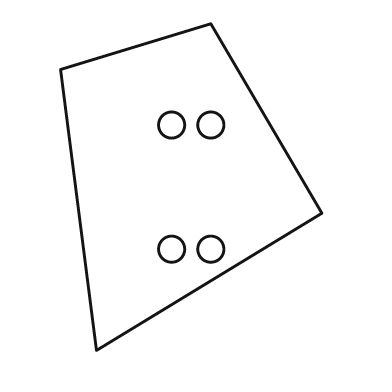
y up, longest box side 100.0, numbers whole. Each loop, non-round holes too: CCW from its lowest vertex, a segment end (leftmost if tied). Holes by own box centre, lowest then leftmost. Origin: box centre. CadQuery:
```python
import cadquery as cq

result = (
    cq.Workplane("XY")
    .moveTo(-29.0, -50.0)
    .lineTo(40.0, -8.0)
    .lineTo(6.0, 50.0)
    .lineTo(-40.0, 36.0)
    .close()
    .moveTo(-6.0, -19.0)
    .circle(4.0)
    .moveTo(6.0, -19.0)
    .circle(4.0)
    .moveTo(-6.0, 19.0)
    .circle(4.0)
    .moveTo(6.0, 19.0)
    .circle(4.0)
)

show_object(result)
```